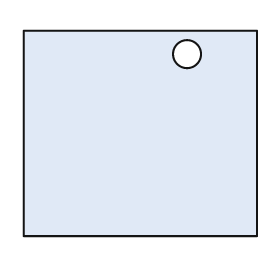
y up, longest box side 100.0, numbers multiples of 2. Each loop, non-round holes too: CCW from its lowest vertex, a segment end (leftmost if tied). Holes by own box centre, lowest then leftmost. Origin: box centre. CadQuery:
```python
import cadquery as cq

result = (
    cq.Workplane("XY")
    .moveTo(-50.0, -44.0)
    .lineTo(50.0, -44.0)
    .lineTo(50.0, 44.0)
    .lineTo(-50.0, 44.0)
    .close()
    .moveTo(20.0, 34.0)
    .circle(6.0)
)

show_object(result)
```